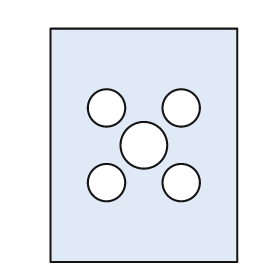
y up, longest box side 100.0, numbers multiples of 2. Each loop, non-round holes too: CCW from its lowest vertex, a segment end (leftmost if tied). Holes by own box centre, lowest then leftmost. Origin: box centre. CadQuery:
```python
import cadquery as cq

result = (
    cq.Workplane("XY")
    .moveTo(-40.0, -50.0)
    .lineTo(40.0, -50.0)
    .lineTo(40.0, 50.0)
    .lineTo(-40.0, 50.0)
    .close()
    .moveTo(-16.0, -16.0)
    .circle(8.0)
    .moveTo(16.0, -16.0)
    .circle(8.0)
    .moveTo(0.0, 0.0)
    .circle(10.0)
    .moveTo(-16.0, 16.0)
    .circle(8.0)
    .moveTo(16.0, 16.0)
    .circle(8.0)
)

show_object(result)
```